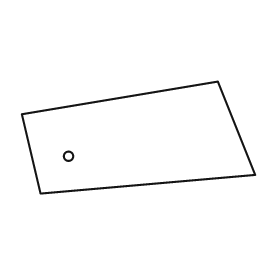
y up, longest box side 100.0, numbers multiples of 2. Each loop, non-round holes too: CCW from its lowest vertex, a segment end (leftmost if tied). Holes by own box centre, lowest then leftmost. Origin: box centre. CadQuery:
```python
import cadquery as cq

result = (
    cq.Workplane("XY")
    .moveTo(-42.0, -24.0)
    .lineTo(50.0, -16.0)
    .lineTo(34.0, 24.0)
    .lineTo(-50.0, 10.0)
    .close()
    .moveTo(-30.0, -8.0)
    .circle(2.0)
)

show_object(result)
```